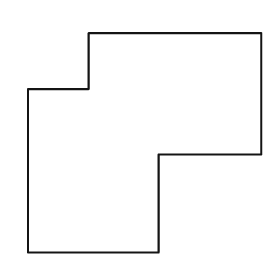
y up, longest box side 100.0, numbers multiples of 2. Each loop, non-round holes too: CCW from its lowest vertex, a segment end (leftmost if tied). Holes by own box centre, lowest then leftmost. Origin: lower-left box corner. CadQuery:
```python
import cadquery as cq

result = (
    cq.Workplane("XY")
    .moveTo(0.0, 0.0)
    .lineTo(56.0, 0.0)
    .lineTo(56.0, 42.0)
    .lineTo(100.0, 42.0)
    .lineTo(100.0, 94.0)
    .lineTo(26.0, 94.0)
    .lineTo(26.0, 70.0)
    .lineTo(0.0, 70.0)
    .close()
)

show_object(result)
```